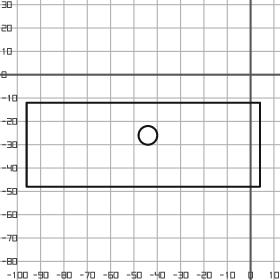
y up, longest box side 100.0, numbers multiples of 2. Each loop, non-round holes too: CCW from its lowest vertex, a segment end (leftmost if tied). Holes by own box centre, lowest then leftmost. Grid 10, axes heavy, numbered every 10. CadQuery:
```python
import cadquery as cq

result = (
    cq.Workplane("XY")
    .moveTo(-96.0, -48.0)
    .lineTo(4.0, -48.0)
    .lineTo(4.0, -12.0)
    .lineTo(-96.0, -12.0)
    .close()
    .moveTo(-44.0, -26.0)
    .circle(4.0)
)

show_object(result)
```